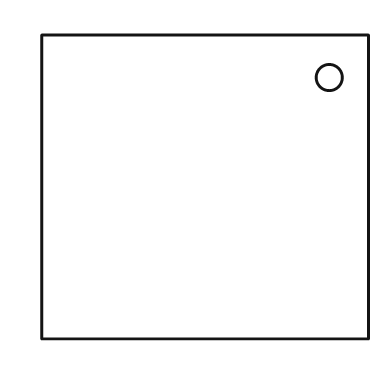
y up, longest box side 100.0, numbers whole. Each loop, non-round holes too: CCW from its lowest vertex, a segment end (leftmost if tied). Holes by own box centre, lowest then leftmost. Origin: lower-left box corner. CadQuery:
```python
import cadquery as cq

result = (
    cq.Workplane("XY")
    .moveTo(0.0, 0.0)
    .lineTo(100.0, 0.0)
    .lineTo(100.0, 93.0)
    .lineTo(0.0, 93.0)
    .close()
    .moveTo(88.0, 80.0)
    .circle(4.0)
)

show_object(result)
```